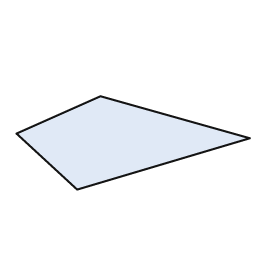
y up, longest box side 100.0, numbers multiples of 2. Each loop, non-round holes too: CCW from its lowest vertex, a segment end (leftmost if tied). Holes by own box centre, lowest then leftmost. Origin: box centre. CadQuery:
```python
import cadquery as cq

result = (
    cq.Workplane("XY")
    .moveTo(-24.0, -20.0)
    .lineTo(50.0, 2.0)
    .lineTo(-14.0, 20.0)
    .lineTo(-50.0, 4.0)
    .close()
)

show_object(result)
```